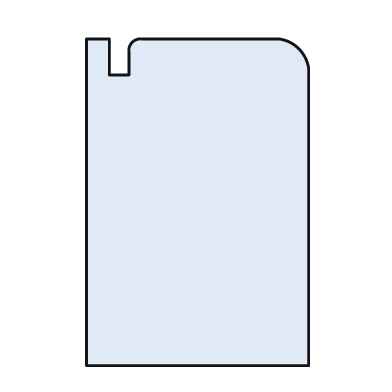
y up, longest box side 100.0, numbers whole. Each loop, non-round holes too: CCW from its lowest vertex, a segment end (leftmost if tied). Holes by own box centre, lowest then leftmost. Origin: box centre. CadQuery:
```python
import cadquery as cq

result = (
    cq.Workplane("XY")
    .moveTo(-34.0, -50.0)
    .lineTo(34.0, -50.0)
    .lineTo(34.0, 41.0)
    .threePointArc((31.0, 47.0), (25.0, 50.0))
    .lineTo(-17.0, 50.0)
    .threePointArc((-20.0, 49.0), (-21.0, 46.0))
    .lineTo(-21.0, 39.0)
    .lineTo(-27.0, 39.0)
    .lineTo(-27.0, 50.0)
    .lineTo(-34.0, 50.0)
    .close()
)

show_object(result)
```